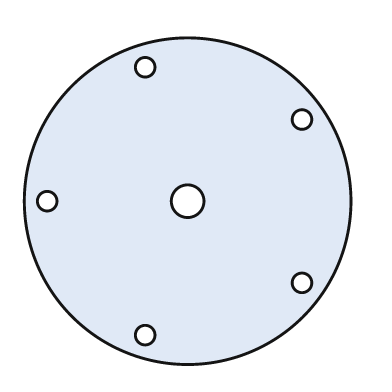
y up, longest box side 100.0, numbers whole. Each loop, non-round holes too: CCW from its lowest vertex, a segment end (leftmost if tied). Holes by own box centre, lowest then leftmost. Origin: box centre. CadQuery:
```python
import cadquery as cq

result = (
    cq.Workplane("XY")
    .moveTo(0.0, 0.0)
    .circle(50.0)
    .moveTo(-13.0, -41.0)
    .circle(3.0)
    .moveTo(35.0, -25.0)
    .circle(3.0)
    .moveTo(-43.0, 0.0)
    .circle(3.0)
    .moveTo(0.0, 0.0)
    .circle(5.0)
    .moveTo(35.0, 25.0)
    .circle(3.0)
    .moveTo(-13.0, 41.0)
    .circle(3.0)
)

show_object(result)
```